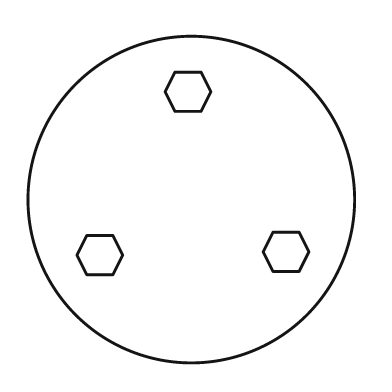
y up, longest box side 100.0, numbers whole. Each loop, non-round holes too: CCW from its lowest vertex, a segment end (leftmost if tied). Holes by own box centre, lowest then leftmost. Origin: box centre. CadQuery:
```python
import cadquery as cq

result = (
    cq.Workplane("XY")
    .moveTo(0.0, 0.0)
    .circle(50.0)
    .moveTo(-32.0, -23.0)
    .lineTo(-24.0, -23.0)
    .lineTo(-21.0, -17.0)
    .lineTo(-24.0, -11.0)
    .lineTo(-32.0, -11.0)
    .lineTo(-35.0, -17.0)
    .close()
    .moveTo(25.0, -22.0)
    .lineTo(33.0, -22.0)
    .lineTo(36.0, -16.0)
    .lineTo(33.0, -10.0)
    .lineTo(25.0, -10.0)
    .lineTo(22.0, -16.0)
    .close()
    .moveTo(-5.0, 27.0)
    .lineTo(3.0, 27.0)
    .lineTo(6.0, 33.0)
    .lineTo(3.0, 39.0)
    .lineTo(-5.0, 39.0)
    .lineTo(-8.0, 33.0)
    .close()
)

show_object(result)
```